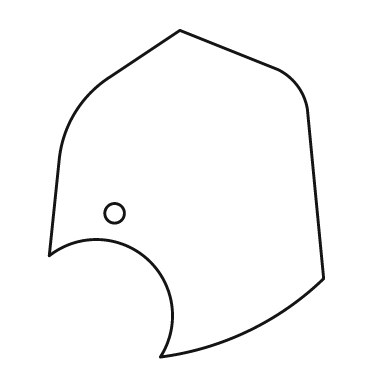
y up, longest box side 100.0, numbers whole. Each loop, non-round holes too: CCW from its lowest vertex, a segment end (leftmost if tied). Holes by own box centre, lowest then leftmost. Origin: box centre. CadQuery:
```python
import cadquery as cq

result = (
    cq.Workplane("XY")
    .moveTo(-8.0, -50.0)
    .threePointArc((19.0, -42.0), (42.0, -26.0))
    .lineTo(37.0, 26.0)
    .threePointArc((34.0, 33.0), (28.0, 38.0))
    .lineTo(-2.0, 50.0)
    .lineTo(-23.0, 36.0)
    .threePointArc((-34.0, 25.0), (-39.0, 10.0))
    .lineTo(-42.0, -19.0)
    .threePointArc((-12.0, -20.0), (-8.0, -50.0))
    .close()
    .moveTo(-22.0, -6.0)
    .circle(3.0)
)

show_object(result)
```